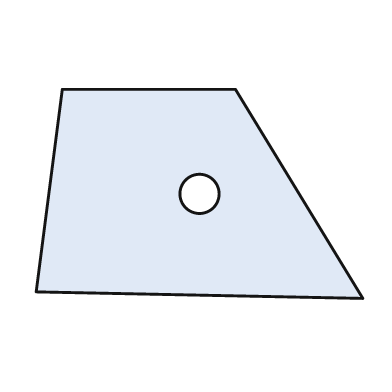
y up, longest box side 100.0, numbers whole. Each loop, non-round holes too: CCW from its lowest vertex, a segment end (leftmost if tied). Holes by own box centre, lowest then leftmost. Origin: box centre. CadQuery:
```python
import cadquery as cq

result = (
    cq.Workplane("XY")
    .moveTo(50.0, -32.0)
    .lineTo(11.0, 32.0)
    .lineTo(-42.0, 32.0)
    .lineTo(-50.0, -30.0)
    .close()
    .moveTo(0.0, 0.0)
    .circle(6.0)
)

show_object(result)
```